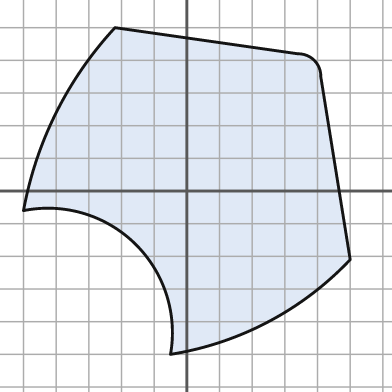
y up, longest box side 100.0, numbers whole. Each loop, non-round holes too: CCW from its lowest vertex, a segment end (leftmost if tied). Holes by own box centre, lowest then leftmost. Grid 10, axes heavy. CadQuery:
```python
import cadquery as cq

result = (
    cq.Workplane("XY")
    .moveTo(-5.0, -50.0)
    .threePointArc((25.0, -40.0), (50.0, -21.0))
    .lineTo(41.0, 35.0)
    .threePointArc((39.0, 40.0), (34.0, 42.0))
    .lineTo(-22.0, 50.0)
    .threePointArc((-40.0, 24.0), (-50.0, -6.0))
    .threePointArc((-16.0, -16.0), (-5.0, -50.0))
    .close()
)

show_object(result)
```